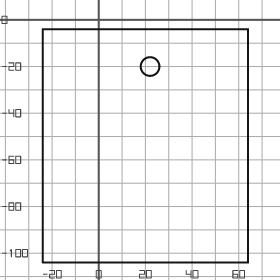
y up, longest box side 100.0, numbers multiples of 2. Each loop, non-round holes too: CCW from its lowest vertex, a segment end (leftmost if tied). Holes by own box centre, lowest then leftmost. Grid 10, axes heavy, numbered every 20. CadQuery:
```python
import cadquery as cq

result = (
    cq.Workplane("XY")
    .moveTo(-24.0, -104.0)
    .lineTo(64.0, -104.0)
    .lineTo(64.0, -4.0)
    .lineTo(-24.0, -4.0)
    .close()
    .moveTo(22.0, -20.0)
    .circle(4.0)
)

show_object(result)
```